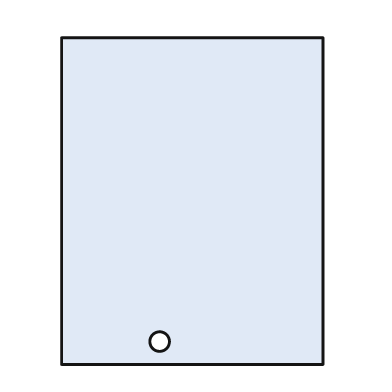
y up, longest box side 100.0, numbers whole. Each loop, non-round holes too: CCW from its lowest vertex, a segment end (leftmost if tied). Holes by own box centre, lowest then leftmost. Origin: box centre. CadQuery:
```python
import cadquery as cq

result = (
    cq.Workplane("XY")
    .moveTo(-40.0, -50.0)
    .lineTo(40.0, -50.0)
    .lineTo(40.0, 50.0)
    .lineTo(-40.0, 50.0)
    .close()
    .moveTo(-10.0, -43.0)
    .circle(3.0)
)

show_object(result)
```